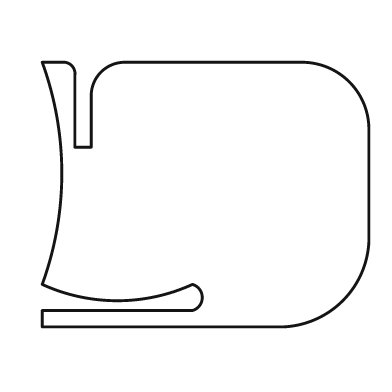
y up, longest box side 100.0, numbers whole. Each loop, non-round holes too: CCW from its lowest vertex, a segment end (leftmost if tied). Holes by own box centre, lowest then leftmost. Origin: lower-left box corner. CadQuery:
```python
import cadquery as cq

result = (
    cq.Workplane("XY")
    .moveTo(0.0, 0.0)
    .lineTo(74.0, 0.0)
    .threePointArc((92.0, 8.0), (100.0, 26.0))
    .lineTo(100.0, 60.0)
    .threePointArc((94.0, 75.0), (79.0, 81.0))
    .lineTo(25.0, 81.0)
    .threePointArc((18.0, 78.0), (15.0, 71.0))
    .lineTo(15.0, 55.0)
    .lineTo(10.0, 55.0)
    .lineTo(10.0, 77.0)
    .threePointArc((9.0, 80.0), (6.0, 81.0))
    .lineTo(0.0, 81.0)
    .threePointArc((6.0, 47.0), (0.0, 13.0))
    .threePointArc((23.0, 8.0), (46.0, 13.0))
    .threePointArc((49.0, 9.0), (46.0, 5.0))
    .lineTo(0.0, 5.0)
    .close()
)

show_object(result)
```